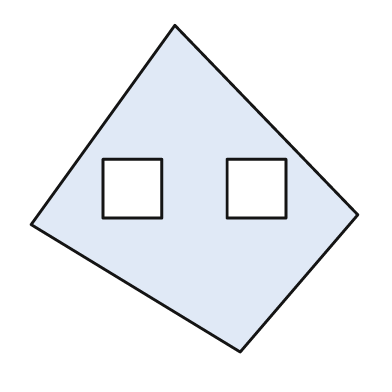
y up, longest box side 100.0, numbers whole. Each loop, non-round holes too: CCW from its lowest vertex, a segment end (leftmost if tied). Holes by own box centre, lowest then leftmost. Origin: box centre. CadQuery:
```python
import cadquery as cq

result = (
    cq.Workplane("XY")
    .moveTo(14.0, -50.0)
    .lineTo(50.0, -8.0)
    .lineTo(-6.0, 50.0)
    .lineTo(-50.0, -11.0)
    .close()
    .moveTo(-28.0, -9.0)
    .lineTo(-10.0, -9.0)
    .lineTo(-10.0, 9.0)
    .lineTo(-28.0, 9.0)
    .close()
    .moveTo(10.0, -9.0)
    .lineTo(28.0, -9.0)
    .lineTo(28.0, 9.0)
    .lineTo(10.0, 9.0)
    .close()
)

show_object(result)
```